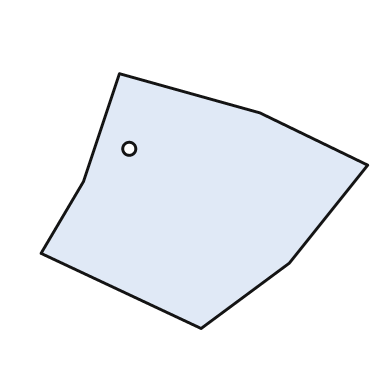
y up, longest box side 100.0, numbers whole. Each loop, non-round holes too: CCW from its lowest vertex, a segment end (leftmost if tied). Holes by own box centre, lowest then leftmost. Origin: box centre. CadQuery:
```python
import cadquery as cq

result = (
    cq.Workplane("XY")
    .moveTo(-1.0, -39.0)
    .lineTo(26.0, -19.0)
    .lineTo(50.0, 11.0)
    .lineTo(17.0, 27.0)
    .lineTo(-26.0, 39.0)
    .lineTo(-37.0, 6.0)
    .lineTo(-50.0, -16.0)
    .close()
    .moveTo(-23.0, 16.0)
    .circle(2.0)
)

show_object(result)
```